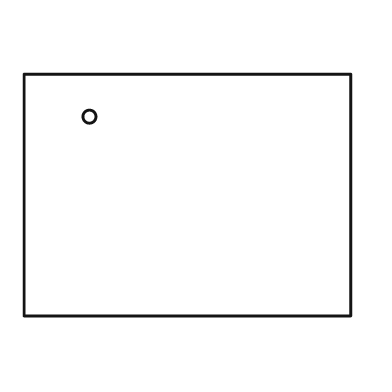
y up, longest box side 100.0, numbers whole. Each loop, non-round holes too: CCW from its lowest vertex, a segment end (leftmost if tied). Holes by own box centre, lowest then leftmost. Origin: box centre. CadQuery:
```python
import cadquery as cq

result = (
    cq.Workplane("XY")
    .moveTo(-50.0, -37.0)
    .lineTo(50.0, -37.0)
    .lineTo(50.0, 37.0)
    .lineTo(-50.0, 37.0)
    .close()
    .moveTo(-30.0, 24.0)
    .circle(2.0)
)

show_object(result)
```